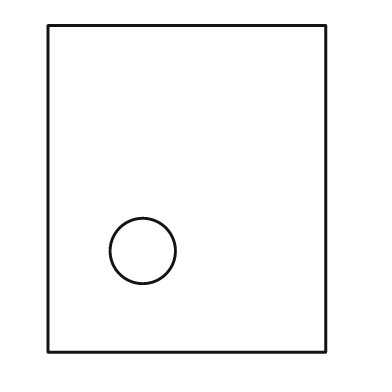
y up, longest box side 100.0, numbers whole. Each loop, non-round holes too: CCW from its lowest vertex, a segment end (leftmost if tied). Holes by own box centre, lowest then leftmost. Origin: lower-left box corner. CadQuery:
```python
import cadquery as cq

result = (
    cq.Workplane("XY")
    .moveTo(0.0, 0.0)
    .lineTo(85.0, 0.0)
    .lineTo(85.0, 100.0)
    .lineTo(0.0, 100.0)
    .close()
    .moveTo(29.0, 31.0)
    .circle(10.0)
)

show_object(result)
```